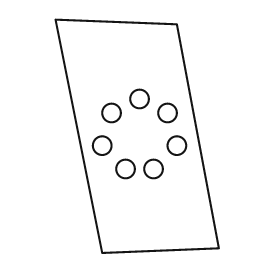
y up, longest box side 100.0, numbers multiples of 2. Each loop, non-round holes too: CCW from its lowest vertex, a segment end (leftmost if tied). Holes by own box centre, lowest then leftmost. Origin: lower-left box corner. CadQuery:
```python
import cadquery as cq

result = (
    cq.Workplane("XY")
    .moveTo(20.0, 0.0)
    .lineTo(70.0, 2.0)
    .lineTo(52.0, 98.0)
    .lineTo(0.0, 100.0)
    .close()
    .moveTo(30.0, 36.0)
    .circle(4.0)
    .moveTo(42.0, 36.0)
    .circle(4.0)
    .moveTo(20.0, 46.0)
    .circle(4.0)
    .moveTo(52.0, 46.0)
    .circle(4.0)
    .moveTo(24.0, 60.0)
    .circle(4.0)
    .moveTo(48.0, 60.0)
    .circle(4.0)
    .moveTo(36.0, 66.0)
    .circle(4.0)
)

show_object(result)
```